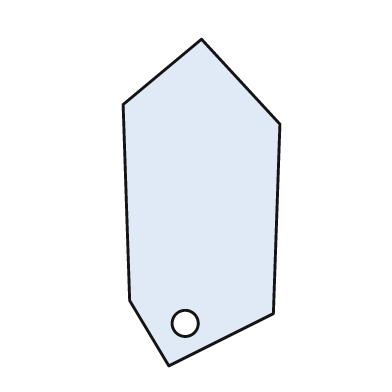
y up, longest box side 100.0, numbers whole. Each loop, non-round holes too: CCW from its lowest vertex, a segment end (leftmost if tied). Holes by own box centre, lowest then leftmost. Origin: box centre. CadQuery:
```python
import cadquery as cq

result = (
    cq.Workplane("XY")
    .moveTo(-10.0, -50.0)
    .lineTo(22.0, -34.0)
    .lineTo(24.0, 24.0)
    .lineTo(0.0, 50.0)
    .lineTo(-24.0, 30.0)
    .lineTo(-22.0, -30.0)
    .close()
    .moveTo(-5.0, -37.0)
    .circle(4.0)
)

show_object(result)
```